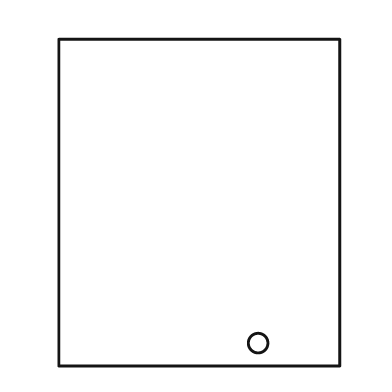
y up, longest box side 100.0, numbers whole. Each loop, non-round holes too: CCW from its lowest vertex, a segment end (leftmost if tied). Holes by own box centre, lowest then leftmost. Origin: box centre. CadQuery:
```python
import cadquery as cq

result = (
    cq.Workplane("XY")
    .moveTo(-43.0, -50.0)
    .lineTo(43.0, -50.0)
    .lineTo(43.0, 50.0)
    .lineTo(-43.0, 50.0)
    .close()
    .moveTo(18.0, -43.0)
    .circle(3.0)
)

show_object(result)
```